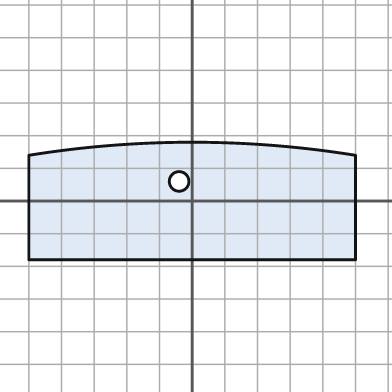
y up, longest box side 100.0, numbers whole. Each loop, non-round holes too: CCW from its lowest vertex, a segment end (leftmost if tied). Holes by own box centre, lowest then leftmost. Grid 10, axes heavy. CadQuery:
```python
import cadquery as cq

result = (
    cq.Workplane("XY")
    .moveTo(-50.0, -18.0)
    .lineTo(50.0, -18.0)
    .lineTo(50.0, 14.0)
    .threePointArc((0.0, 18.0), (-50.0, 14.0))
    .close()
    .moveTo(-4.0, 6.0)
    .circle(3.0)
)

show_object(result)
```